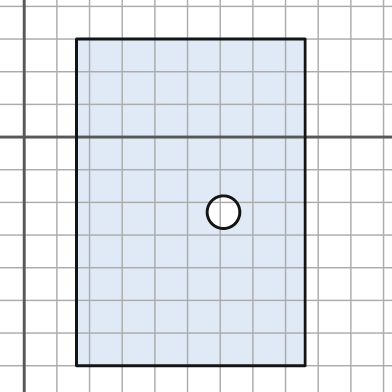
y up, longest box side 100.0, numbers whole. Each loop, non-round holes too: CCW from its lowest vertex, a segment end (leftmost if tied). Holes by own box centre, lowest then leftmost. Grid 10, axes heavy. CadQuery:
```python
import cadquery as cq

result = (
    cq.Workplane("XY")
    .moveTo(16.0, -70.0)
    .lineTo(86.0, -70.0)
    .lineTo(86.0, 30.0)
    .lineTo(16.0, 30.0)
    .close()
    .moveTo(61.0, -23.0)
    .circle(5.0)
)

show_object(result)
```